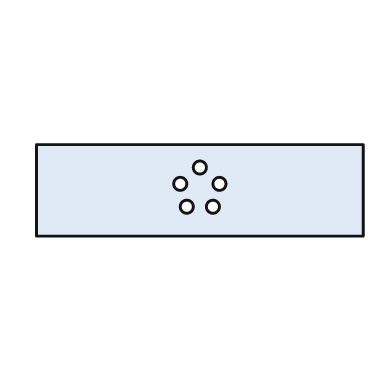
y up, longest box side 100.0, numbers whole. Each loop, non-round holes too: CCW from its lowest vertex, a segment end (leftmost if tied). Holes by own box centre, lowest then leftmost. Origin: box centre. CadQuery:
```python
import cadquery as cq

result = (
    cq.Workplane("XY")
    .moveTo(-50.0, -14.0)
    .lineTo(50.0, -14.0)
    .lineTo(50.0, 14.0)
    .lineTo(-50.0, 14.0)
    .close()
    .moveTo(-4.0, -5.0)
    .circle(2.0)
    .moveTo(4.0, -5.0)
    .circle(2.0)
    .moveTo(-6.0, 2.0)
    .circle(2.0)
    .moveTo(6.0, 2.0)
    .circle(2.0)
    .moveTo(0.0, 7.0)
    .circle(2.0)
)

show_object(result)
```